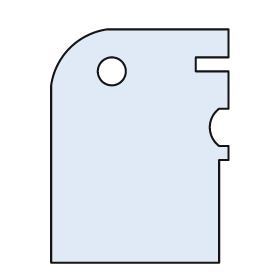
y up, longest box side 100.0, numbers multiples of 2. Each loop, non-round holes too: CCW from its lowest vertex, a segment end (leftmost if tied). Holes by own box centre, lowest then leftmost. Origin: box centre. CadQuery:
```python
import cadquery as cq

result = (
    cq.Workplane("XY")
    .moveTo(-38.0, -50.0)
    .lineTo(34.0, -50.0)
    .lineTo(34.0, -6.0)
    .lineTo(38.0, -6.0)
    .lineTo(38.0, 0.0)
    .lineTo(34.0, 0.0)
    .threePointArc((30.0, 8.0), (34.0, 16.0))
    .lineTo(38.0, 16.0)
    .lineTo(38.0, 32.0)
    .lineTo(24.0, 32.0)
    .lineTo(24.0, 38.0)
    .lineTo(38.0, 38.0)
    .lineTo(38.0, 50.0)
    .lineTo(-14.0, 50.0)
    .threePointArc((-30.0, 42.0), (-38.0, 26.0))
    .close()
    .moveTo(-12.0, 32.0)
    .circle(6.0)
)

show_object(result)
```